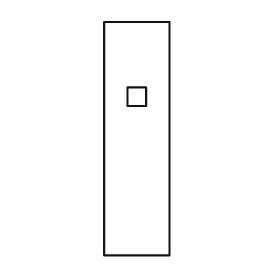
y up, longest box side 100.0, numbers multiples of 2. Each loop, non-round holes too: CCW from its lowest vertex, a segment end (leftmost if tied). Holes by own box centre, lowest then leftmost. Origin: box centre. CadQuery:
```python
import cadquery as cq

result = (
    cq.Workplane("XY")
    .moveTo(-14.0, -50.0)
    .lineTo(14.0, -50.0)
    .lineTo(14.0, 50.0)
    .lineTo(-14.0, 50.0)
    .close()
    .moveTo(-4.0, 14.0)
    .lineTo(4.0, 14.0)
    .lineTo(4.0, 22.0)
    .lineTo(-4.0, 22.0)
    .close()
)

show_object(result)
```